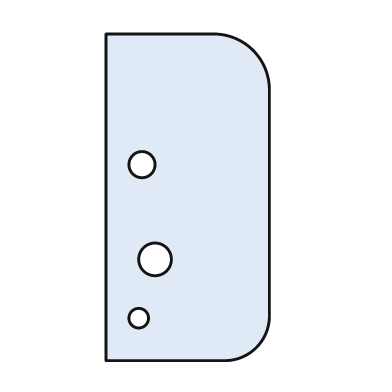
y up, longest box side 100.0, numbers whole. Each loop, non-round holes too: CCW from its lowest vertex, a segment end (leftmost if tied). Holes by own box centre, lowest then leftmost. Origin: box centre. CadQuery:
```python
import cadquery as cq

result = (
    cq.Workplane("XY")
    .moveTo(-25.0, -50.0)
    .lineTo(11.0, -50.0)
    .threePointArc((21.0, -46.0), (25.0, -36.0))
    .lineTo(25.0, 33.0)
    .threePointArc((20.0, 45.0), (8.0, 50.0))
    .lineTo(-25.0, 50.0)
    .close()
    .moveTo(-15.0, -37.0)
    .circle(3.0)
    .moveTo(-10.0, -19.0)
    .circle(5.0)
    .moveTo(-14.0, 10.0)
    .circle(4.0)
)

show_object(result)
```